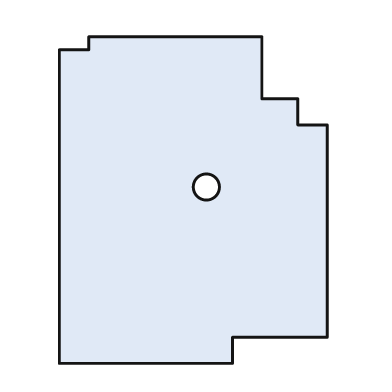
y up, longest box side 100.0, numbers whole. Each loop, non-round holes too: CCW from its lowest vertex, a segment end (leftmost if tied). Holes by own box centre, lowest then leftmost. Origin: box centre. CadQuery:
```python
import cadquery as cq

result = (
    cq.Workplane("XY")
    .moveTo(-41.0, -50.0)
    .lineTo(12.0, -50.0)
    .lineTo(12.0, -42.0)
    .lineTo(41.0, -42.0)
    .lineTo(41.0, 23.0)
    .lineTo(32.0, 23.0)
    .lineTo(32.0, 31.0)
    .lineTo(21.0, 31.0)
    .lineTo(21.0, 50.0)
    .lineTo(-32.0, 50.0)
    .lineTo(-32.0, 46.0)
    .lineTo(-41.0, 46.0)
    .close()
    .moveTo(4.0, 4.0)
    .circle(4.0)
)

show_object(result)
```